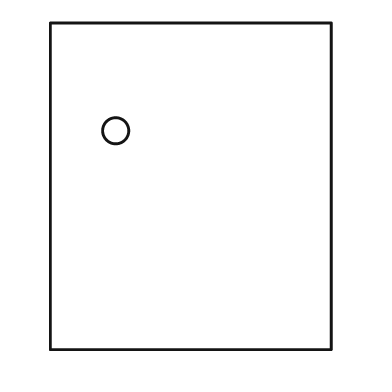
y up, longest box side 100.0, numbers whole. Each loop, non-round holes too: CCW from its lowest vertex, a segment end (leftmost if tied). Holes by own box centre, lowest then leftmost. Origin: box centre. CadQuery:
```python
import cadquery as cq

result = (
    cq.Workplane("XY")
    .moveTo(-43.0, -50.0)
    .lineTo(43.0, -50.0)
    .lineTo(43.0, 50.0)
    .lineTo(-43.0, 50.0)
    .close()
    .moveTo(-23.0, 17.0)
    .circle(4.0)
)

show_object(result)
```